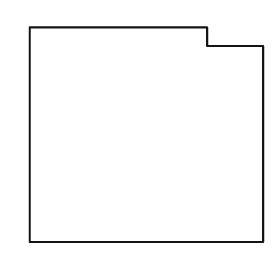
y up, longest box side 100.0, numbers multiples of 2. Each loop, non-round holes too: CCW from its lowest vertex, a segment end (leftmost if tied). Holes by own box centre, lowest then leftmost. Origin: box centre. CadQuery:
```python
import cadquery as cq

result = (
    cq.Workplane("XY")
    .moveTo(-50.0, -46.0)
    .lineTo(50.0, -46.0)
    .lineTo(50.0, 38.0)
    .lineTo(26.0, 38.0)
    .lineTo(26.0, 46.0)
    .lineTo(-50.0, 46.0)
    .close()
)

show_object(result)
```